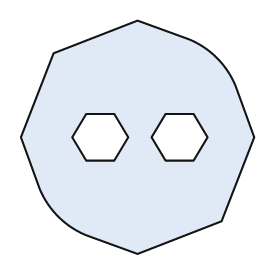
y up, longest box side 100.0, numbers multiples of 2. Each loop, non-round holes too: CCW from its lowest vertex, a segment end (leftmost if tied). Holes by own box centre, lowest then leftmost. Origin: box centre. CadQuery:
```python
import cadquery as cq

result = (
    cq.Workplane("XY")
    .moveTo(0.0, -50.0)
    .lineTo(36.0, -36.0)
    .lineTo(50.0, 0.0)
    .lineTo(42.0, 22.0)
    .threePointArc((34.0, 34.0), (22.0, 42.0))
    .lineTo(0.0, 50.0)
    .lineTo(-36.0, 36.0)
    .lineTo(-50.0, 0.0)
    .lineTo(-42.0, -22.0)
    .threePointArc((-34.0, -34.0), (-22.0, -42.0))
    .close()
    .moveTo(-22.0, -10.0)
    .lineTo(-10.0, -10.0)
    .lineTo(-4.0, 0.0)
    .lineTo(-10.0, 10.0)
    .lineTo(-22.0, 10.0)
    .lineTo(-28.0, 0.0)
    .close()
    .moveTo(12.0, -10.0)
    .lineTo(24.0, -10.0)
    .lineTo(30.0, 0.0)
    .lineTo(24.0, 10.0)
    .lineTo(12.0, 10.0)
    .lineTo(6.0, 0.0)
    .close()
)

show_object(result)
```